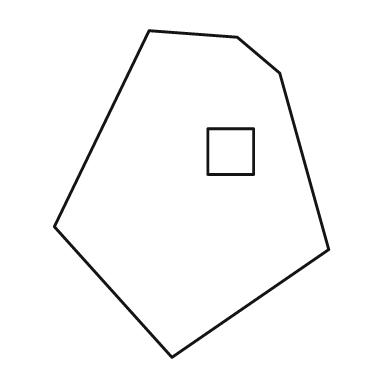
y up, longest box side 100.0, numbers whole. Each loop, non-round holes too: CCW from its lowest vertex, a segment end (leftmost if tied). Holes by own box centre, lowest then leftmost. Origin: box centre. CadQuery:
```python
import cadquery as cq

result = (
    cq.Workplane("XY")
    .moveTo(-6.0, -50.0)
    .lineTo(42.0, -17.0)
    .lineTo(27.0, 37.0)
    .lineTo(14.0, 48.0)
    .lineTo(-13.0, 50.0)
    .lineTo(-42.0, -10.0)
    .close()
    .moveTo(5.0, 6.0)
    .lineTo(19.0, 6.0)
    .lineTo(19.0, 20.0)
    .lineTo(5.0, 20.0)
    .close()
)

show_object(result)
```